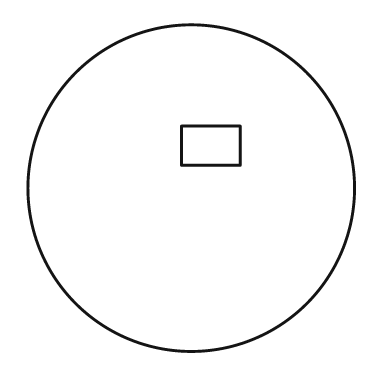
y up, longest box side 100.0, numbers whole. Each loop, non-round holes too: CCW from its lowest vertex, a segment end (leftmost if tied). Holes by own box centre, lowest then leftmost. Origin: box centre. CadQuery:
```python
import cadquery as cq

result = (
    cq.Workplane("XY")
    .moveTo(0.0, 0.0)
    .circle(50.0)
    .moveTo(-3.0, 7.0)
    .lineTo(15.0, 7.0)
    .lineTo(15.0, 19.0)
    .lineTo(-3.0, 19.0)
    .close()
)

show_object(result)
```